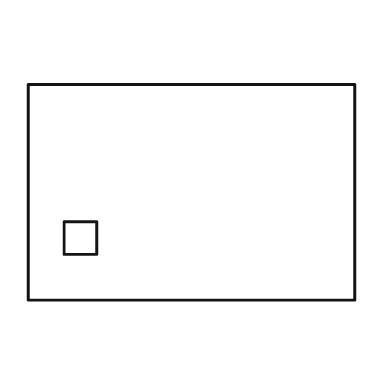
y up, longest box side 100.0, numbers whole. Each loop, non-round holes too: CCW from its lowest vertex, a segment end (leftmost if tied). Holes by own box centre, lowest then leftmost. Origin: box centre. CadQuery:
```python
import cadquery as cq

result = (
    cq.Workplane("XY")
    .moveTo(-50.0, -33.0)
    .lineTo(50.0, -33.0)
    .lineTo(50.0, 33.0)
    .lineTo(-50.0, 33.0)
    .close()
    .moveTo(-39.0, -19.0)
    .lineTo(-29.0, -19.0)
    .lineTo(-29.0, -9.0)
    .lineTo(-39.0, -9.0)
    .close()
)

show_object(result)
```